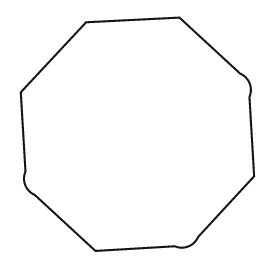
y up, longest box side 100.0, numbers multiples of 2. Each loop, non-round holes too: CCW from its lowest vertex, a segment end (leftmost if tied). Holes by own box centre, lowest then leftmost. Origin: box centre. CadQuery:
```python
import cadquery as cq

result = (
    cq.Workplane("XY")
    .moveTo(-18.0, -50.0)
    .lineTo(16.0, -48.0)
    .threePointArc((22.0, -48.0), (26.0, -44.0))
    .lineTo(50.0, -18.0)
    .lineTo(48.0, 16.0)
    .threePointArc((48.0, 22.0), (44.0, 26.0))
    .lineTo(18.0, 50.0)
    .lineTo(-22.0, 48.0)
    .lineTo(-50.0, 18.0)
    .lineTo(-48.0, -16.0)
    .threePointArc((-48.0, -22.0), (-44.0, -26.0))
    .close()
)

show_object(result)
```